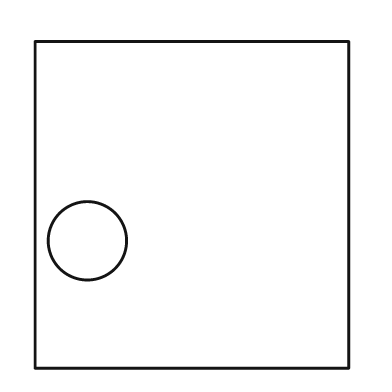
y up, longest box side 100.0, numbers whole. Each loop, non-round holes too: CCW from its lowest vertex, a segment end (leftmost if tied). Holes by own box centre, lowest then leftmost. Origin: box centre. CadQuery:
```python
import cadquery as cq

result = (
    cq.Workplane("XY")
    .moveTo(-48.0, -50.0)
    .lineTo(48.0, -50.0)
    .lineTo(48.0, 50.0)
    .lineTo(-48.0, 50.0)
    .close()
    .moveTo(-32.0, -11.0)
    .circle(12.0)
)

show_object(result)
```